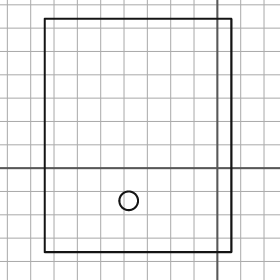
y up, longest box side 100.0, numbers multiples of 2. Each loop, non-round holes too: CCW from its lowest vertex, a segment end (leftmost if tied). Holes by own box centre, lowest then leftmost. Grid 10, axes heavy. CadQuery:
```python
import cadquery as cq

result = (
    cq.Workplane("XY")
    .moveTo(-74.0, -36.0)
    .lineTo(6.0, -36.0)
    .lineTo(6.0, 64.0)
    .lineTo(-74.0, 64.0)
    .close()
    .moveTo(-38.0, -14.0)
    .circle(4.0)
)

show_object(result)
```